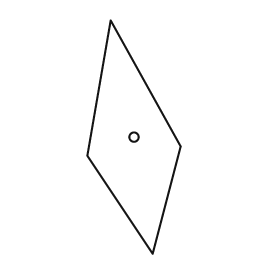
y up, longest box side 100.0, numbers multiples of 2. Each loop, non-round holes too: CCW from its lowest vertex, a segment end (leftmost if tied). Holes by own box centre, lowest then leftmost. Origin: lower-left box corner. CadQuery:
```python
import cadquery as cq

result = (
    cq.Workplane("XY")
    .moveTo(28.0, 0.0)
    .lineTo(40.0, 46.0)
    .lineTo(10.0, 100.0)
    .lineTo(0.0, 42.0)
    .close()
    .moveTo(20.0, 50.0)
    .circle(2.0)
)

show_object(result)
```